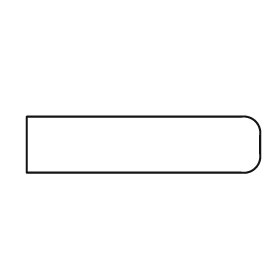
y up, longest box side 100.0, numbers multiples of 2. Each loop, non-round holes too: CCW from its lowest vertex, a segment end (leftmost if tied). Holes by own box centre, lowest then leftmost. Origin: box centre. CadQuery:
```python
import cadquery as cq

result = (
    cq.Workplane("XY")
    .moveTo(-50.0, -12.0)
    .lineTo(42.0, -12.0)
    .threePointArc((48.0, -10.0), (50.0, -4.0))
    .lineTo(50.0, 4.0)
    .threePointArc((48.0, 10.0), (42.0, 12.0))
    .lineTo(-50.0, 12.0)
    .close()
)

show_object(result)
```